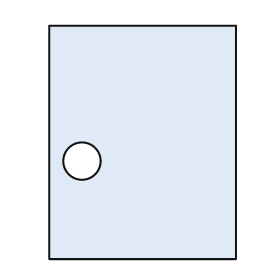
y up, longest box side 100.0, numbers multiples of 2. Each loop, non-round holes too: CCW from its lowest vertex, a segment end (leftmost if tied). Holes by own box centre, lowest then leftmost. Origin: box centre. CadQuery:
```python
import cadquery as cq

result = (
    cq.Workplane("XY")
    .moveTo(-40.0, -50.0)
    .lineTo(40.0, -50.0)
    .lineTo(40.0, 50.0)
    .lineTo(-40.0, 50.0)
    .close()
    .moveTo(-26.0, -8.0)
    .circle(8.0)
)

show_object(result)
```